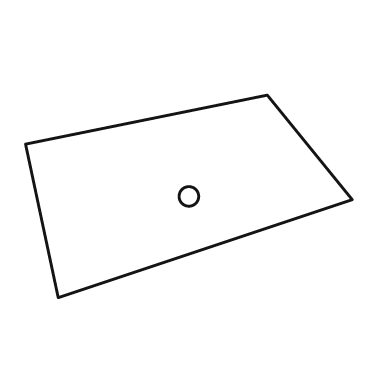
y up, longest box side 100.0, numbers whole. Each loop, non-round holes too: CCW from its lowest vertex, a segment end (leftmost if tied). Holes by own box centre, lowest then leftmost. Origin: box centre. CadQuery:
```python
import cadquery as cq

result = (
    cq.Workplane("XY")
    .moveTo(-40.0, -31.0)
    .lineTo(50.0, -1.0)
    .lineTo(24.0, 31.0)
    .lineTo(-50.0, 16.0)
    .close()
    .moveTo(0.0, 0.0)
    .circle(3.0)
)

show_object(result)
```